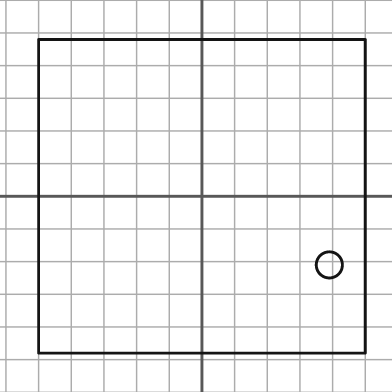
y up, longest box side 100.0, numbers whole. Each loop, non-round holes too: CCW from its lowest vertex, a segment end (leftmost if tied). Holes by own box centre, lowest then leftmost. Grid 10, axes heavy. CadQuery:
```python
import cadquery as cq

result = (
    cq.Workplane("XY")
    .moveTo(-50.0, -48.0)
    .lineTo(50.0, -48.0)
    .lineTo(50.0, 48.0)
    .lineTo(-50.0, 48.0)
    .close()
    .moveTo(39.0, -21.0)
    .circle(4.0)
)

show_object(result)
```